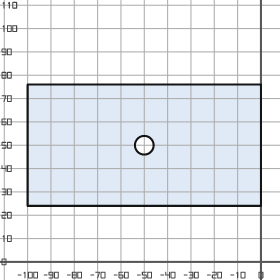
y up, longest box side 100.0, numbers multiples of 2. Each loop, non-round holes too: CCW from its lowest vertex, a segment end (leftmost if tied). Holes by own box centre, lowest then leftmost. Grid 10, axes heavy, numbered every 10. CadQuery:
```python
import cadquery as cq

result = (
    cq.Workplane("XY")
    .moveTo(-100.0, 24.0)
    .lineTo(0.0, 24.0)
    .lineTo(0.0, 76.0)
    .lineTo(-100.0, 76.0)
    .close()
    .moveTo(-50.0, 50.0)
    .circle(4.0)
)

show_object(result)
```